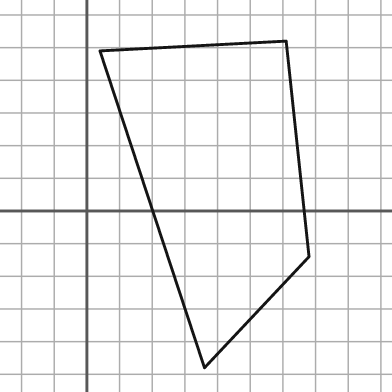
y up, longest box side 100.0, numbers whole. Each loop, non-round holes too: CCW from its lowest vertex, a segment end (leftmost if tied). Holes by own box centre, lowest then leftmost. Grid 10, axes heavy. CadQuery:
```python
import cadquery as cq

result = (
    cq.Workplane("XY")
    .moveTo(36.0, -48.0)
    .lineTo(68.0, -14.0)
    .lineTo(61.0, 52.0)
    .lineTo(4.0, 49.0)
    .close()
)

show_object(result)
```